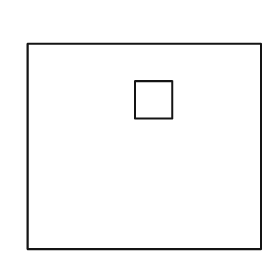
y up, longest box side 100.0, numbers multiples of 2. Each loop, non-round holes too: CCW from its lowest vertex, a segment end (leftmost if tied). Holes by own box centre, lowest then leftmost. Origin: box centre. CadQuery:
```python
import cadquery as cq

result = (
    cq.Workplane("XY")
    .moveTo(-50.0, -44.0)
    .lineTo(50.0, -44.0)
    .lineTo(50.0, 44.0)
    .lineTo(-50.0, 44.0)
    .close()
    .moveTo(-4.0, 12.0)
    .lineTo(12.0, 12.0)
    .lineTo(12.0, 28.0)
    .lineTo(-4.0, 28.0)
    .close()
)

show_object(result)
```